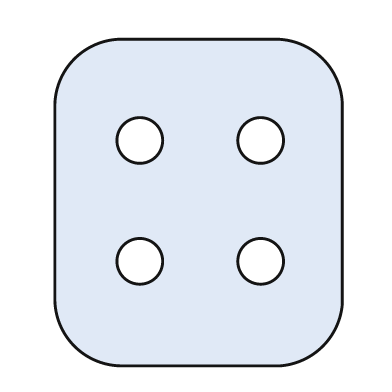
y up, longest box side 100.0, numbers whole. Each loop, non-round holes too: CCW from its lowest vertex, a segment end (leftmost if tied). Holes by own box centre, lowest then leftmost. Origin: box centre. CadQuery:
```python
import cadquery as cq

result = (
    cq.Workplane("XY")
    .moveTo(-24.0, -50.0)
    .lineTo(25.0, -50.0)
    .threePointArc((38.0, -44.0), (44.0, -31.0))
    .lineTo(44.0, 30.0)
    .threePointArc((38.0, 44.0), (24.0, 50.0))
    .lineTo(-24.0, 50.0)
    .threePointArc((-38.0, 44.0), (-44.0, 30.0))
    .lineTo(-44.0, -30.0)
    .threePointArc((-38.0, -44.0), (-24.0, -50.0))
    .close()
    .moveTo(-18.0, -18.0)
    .circle(7.0)
    .moveTo(19.0, -18.0)
    .circle(7.0)
    .moveTo(-18.0, 19.0)
    .circle(7.0)
    .moveTo(19.0, 19.0)
    .circle(7.0)
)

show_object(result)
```